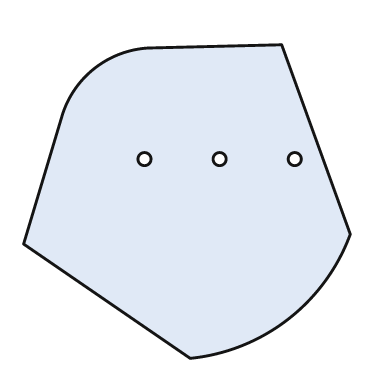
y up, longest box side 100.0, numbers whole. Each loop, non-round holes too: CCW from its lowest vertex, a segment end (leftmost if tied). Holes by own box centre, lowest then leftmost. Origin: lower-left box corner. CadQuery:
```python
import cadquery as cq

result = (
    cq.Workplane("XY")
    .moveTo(51.0, 0.0)
    .threePointArc((81.0, 12.0), (100.0, 38.0))
    .lineTo(79.0, 96.0)
    .lineTo(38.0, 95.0)
    .threePointArc((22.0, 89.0), (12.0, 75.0))
    .lineTo(0.0, 35.0)
    .close()
    .moveTo(37.0, 61.0)
    .circle(2.0)
    .moveTo(60.0, 61.0)
    .circle(2.0)
    .moveTo(83.0, 61.0)
    .circle(2.0)
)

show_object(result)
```